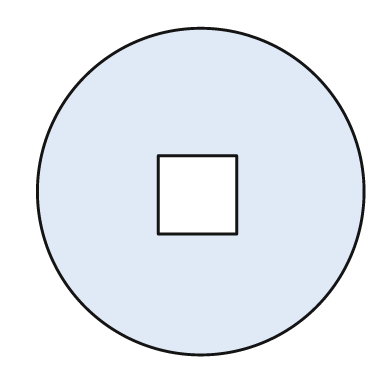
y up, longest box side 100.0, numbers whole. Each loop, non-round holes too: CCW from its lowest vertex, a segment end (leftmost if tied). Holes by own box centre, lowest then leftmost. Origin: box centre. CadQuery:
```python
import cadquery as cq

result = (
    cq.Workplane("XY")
    .moveTo(0.0, 0.0)
    .circle(50.0)
    .moveTo(-13.0, -13.0)
    .lineTo(11.0, -13.0)
    .lineTo(11.0, 11.0)
    .lineTo(-13.0, 11.0)
    .close()
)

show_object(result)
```